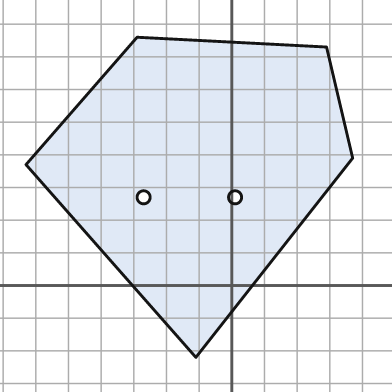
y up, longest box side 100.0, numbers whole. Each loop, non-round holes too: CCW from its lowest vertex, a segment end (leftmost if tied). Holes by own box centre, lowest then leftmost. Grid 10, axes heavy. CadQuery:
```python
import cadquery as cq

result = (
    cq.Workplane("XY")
    .moveTo(-11.0, -22.0)
    .lineTo(37.0, 39.0)
    .lineTo(29.0, 73.0)
    .lineTo(-29.0, 76.0)
    .lineTo(-63.0, 37.0)
    .close()
    .moveTo(-27.0, 27.0)
    .circle(2.0)
    .moveTo(1.0, 27.0)
    .circle(2.0)
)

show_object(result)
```